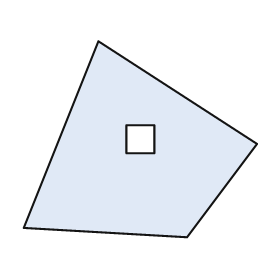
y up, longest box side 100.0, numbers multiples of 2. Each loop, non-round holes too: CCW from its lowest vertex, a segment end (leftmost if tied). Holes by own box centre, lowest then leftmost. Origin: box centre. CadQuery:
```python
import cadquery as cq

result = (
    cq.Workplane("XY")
    .moveTo(20.0, -42.0)
    .lineTo(50.0, -2.0)
    .lineTo(-18.0, 42.0)
    .lineTo(-50.0, -38.0)
    .close()
    .moveTo(-6.0, -6.0)
    .lineTo(6.0, -6.0)
    .lineTo(6.0, 6.0)
    .lineTo(-6.0, 6.0)
    .close()
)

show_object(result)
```